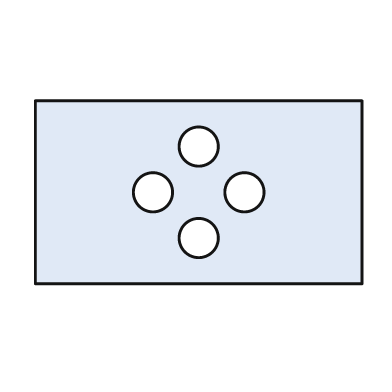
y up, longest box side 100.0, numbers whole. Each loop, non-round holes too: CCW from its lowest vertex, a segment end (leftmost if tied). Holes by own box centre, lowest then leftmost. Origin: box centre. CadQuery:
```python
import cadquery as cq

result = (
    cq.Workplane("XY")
    .moveTo(-50.0, -28.0)
    .lineTo(50.0, -28.0)
    .lineTo(50.0, 28.0)
    .lineTo(-50.0, 28.0)
    .close()
    .moveTo(0.0, -14.0)
    .circle(6.0)
    .moveTo(-14.0, 0.0)
    .circle(6.0)
    .moveTo(14.0, 0.0)
    .circle(6.0)
    .moveTo(0.0, 14.0)
    .circle(6.0)
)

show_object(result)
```